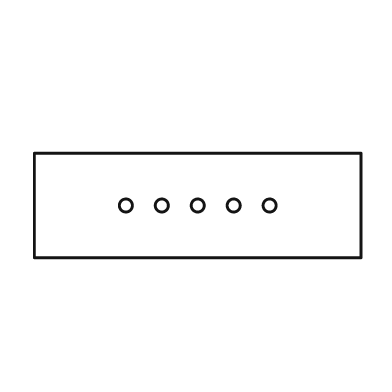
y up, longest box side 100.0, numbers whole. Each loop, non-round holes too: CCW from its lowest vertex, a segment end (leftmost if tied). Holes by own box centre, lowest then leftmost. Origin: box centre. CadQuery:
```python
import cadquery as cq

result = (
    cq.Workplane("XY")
    .moveTo(-50.0, -16.0)
    .lineTo(50.0, -16.0)
    .lineTo(50.0, 16.0)
    .lineTo(-50.0, 16.0)
    .close()
    .moveTo(-22.0, 0.0)
    .circle(2.0)
    .moveTo(-11.0, 0.0)
    .circle(2.0)
    .moveTo(0.0, 0.0)
    .circle(2.0)
    .moveTo(11.0, 0.0)
    .circle(2.0)
    .moveTo(22.0, 0.0)
    .circle(2.0)
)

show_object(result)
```